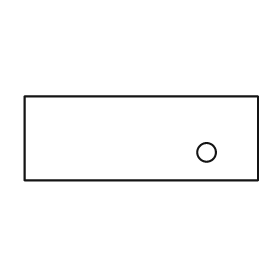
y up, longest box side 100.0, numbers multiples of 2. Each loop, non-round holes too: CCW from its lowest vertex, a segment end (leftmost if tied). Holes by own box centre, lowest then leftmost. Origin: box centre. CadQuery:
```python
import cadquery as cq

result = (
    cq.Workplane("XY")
    .moveTo(-50.0, -18.0)
    .lineTo(50.0, -18.0)
    .lineTo(50.0, 18.0)
    .lineTo(-50.0, 18.0)
    .close()
    .moveTo(28.0, -6.0)
    .circle(4.0)
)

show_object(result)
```